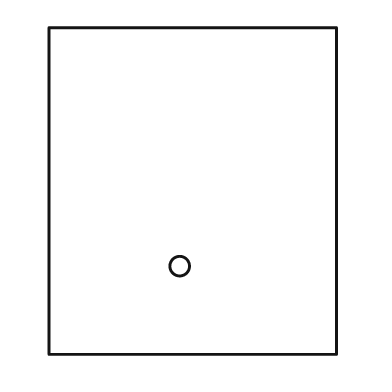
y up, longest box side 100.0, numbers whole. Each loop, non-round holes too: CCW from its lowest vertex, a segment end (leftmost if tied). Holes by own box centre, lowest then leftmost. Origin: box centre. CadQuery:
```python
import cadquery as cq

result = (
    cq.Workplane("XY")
    .moveTo(-44.0, -50.0)
    .lineTo(44.0, -50.0)
    .lineTo(44.0, 50.0)
    .lineTo(-44.0, 50.0)
    .close()
    .moveTo(-4.0, -23.0)
    .circle(3.0)
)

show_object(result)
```